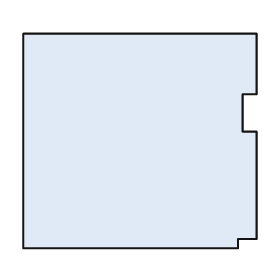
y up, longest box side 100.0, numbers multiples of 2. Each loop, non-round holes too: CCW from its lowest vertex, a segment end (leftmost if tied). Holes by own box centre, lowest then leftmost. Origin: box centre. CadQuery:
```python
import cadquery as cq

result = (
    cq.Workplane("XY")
    .moveTo(-50.0, -46.0)
    .lineTo(42.0, -46.0)
    .lineTo(42.0, -42.0)
    .lineTo(50.0, -42.0)
    .lineTo(50.0, 4.0)
    .lineTo(44.0, 4.0)
    .lineTo(44.0, 20.0)
    .lineTo(50.0, 20.0)
    .lineTo(50.0, 46.0)
    .lineTo(-50.0, 46.0)
    .close()
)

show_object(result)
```